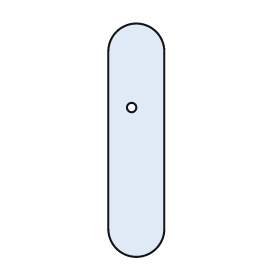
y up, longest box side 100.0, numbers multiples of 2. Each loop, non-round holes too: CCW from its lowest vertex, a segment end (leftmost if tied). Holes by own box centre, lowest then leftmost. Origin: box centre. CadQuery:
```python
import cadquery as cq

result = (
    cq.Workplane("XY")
    .moveTo(-12.0, -38.0)
    .threePointArc((0.0, -50.0), (12.0, -38.0))
    .lineTo(12.0, 38.0)
    .threePointArc((0.0, 50.0), (-12.0, 38.0))
    .close()
    .moveTo(-2.0, 14.0)
    .circle(2.0)
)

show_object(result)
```